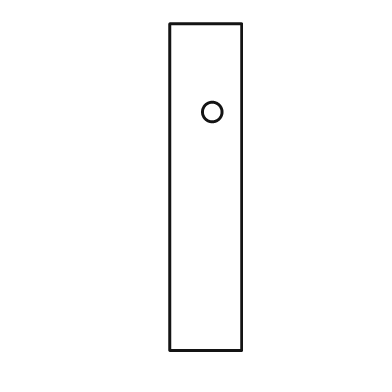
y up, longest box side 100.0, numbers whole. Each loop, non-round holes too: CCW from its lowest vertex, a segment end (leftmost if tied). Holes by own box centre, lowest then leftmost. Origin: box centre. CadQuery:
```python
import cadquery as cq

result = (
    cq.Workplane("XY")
    .moveTo(-11.0, -50.0)
    .lineTo(11.0, -50.0)
    .lineTo(11.0, 50.0)
    .lineTo(-11.0, 50.0)
    .close()
    .moveTo(2.0, 23.0)
    .circle(3.0)
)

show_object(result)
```